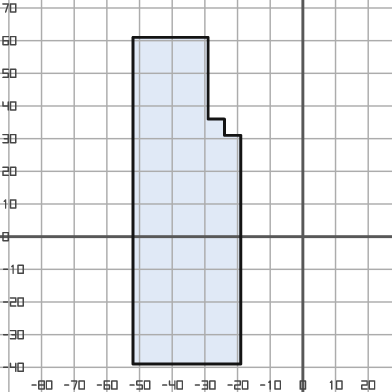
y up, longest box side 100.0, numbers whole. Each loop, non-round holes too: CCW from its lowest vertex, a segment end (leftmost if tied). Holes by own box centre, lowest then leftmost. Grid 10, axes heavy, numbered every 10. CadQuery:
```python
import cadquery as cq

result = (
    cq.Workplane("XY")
    .moveTo(-52.0, -39.0)
    .lineTo(-19.0, -39.0)
    .lineTo(-19.0, 31.0)
    .lineTo(-24.0, 31.0)
    .lineTo(-24.0, 36.0)
    .lineTo(-29.0, 36.0)
    .lineTo(-29.0, 61.0)
    .lineTo(-52.0, 61.0)
    .close()
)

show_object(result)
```